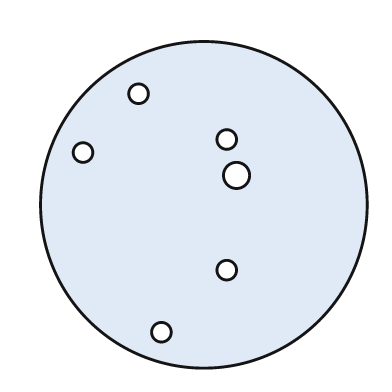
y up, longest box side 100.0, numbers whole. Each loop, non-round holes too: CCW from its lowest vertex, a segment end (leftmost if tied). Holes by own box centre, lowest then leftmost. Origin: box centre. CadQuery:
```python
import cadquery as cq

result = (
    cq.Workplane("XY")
    .moveTo(0.0, 0.0)
    .circle(50.0)
    .moveTo(-13.0, -39.0)
    .circle(3.0)
    .moveTo(7.0, -20.0)
    .circle(3.0)
    .moveTo(10.0, 9.0)
    .circle(4.0)
    .moveTo(-37.0, 16.0)
    .circle(3.0)
    .moveTo(7.0, 20.0)
    .circle(3.0)
    .moveTo(-20.0, 34.0)
    .circle(3.0)
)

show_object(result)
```